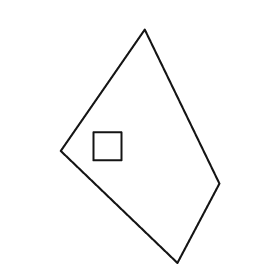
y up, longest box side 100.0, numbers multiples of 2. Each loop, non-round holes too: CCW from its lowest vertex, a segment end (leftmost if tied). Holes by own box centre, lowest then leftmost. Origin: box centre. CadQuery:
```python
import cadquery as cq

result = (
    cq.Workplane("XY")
    .moveTo(16.0, -50.0)
    .lineTo(34.0, -16.0)
    .lineTo(2.0, 50.0)
    .lineTo(-34.0, -2.0)
    .close()
    .moveTo(-20.0, -6.0)
    .lineTo(-8.0, -6.0)
    .lineTo(-8.0, 6.0)
    .lineTo(-20.0, 6.0)
    .close()
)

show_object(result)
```